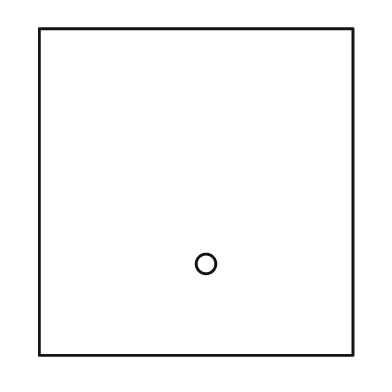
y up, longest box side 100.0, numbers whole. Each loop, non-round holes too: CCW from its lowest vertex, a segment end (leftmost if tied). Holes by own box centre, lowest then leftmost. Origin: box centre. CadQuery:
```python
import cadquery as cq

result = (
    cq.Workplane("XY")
    .moveTo(-48.0, -50.0)
    .lineTo(48.0, -50.0)
    .lineTo(48.0, 50.0)
    .lineTo(-48.0, 50.0)
    .close()
    .moveTo(3.0, -22.0)
    .circle(3.0)
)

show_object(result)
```